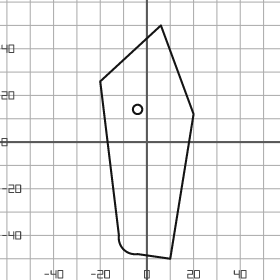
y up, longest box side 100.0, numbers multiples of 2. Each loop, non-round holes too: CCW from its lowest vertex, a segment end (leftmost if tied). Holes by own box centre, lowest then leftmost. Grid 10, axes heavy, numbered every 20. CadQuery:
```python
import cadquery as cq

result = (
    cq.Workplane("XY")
    .moveTo(10.0, -50.0)
    .lineTo(20.0, 12.0)
    .lineTo(6.0, 50.0)
    .lineTo(-20.0, 26.0)
    .lineTo(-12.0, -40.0)
    .threePointArc((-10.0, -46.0), (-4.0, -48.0))
    .close()
    .moveTo(-4.0, 14.0)
    .circle(2.0)
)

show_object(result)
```